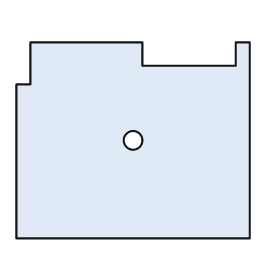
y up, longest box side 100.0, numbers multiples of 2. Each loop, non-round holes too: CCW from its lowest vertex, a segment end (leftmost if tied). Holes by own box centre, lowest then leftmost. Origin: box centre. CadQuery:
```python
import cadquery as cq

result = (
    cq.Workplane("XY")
    .moveTo(-50.0, -42.0)
    .lineTo(50.0, -42.0)
    .lineTo(50.0, 42.0)
    .lineTo(44.0, 42.0)
    .lineTo(44.0, 32.0)
    .lineTo(4.0, 32.0)
    .lineTo(4.0, 42.0)
    .lineTo(-44.0, 42.0)
    .lineTo(-44.0, 24.0)
    .lineTo(-50.0, 24.0)
    .close()
    .moveTo(0.0, 0.0)
    .circle(4.0)
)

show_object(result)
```